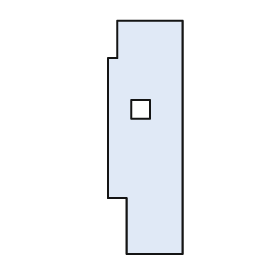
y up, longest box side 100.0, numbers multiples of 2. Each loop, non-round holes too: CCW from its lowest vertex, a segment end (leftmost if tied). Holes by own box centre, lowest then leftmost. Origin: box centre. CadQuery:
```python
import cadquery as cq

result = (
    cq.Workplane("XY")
    .moveTo(-8.0, -50.0)
    .lineTo(16.0, -50.0)
    .lineTo(16.0, 50.0)
    .lineTo(-12.0, 50.0)
    .lineTo(-12.0, 34.0)
    .lineTo(-16.0, 34.0)
    .lineTo(-16.0, -26.0)
    .lineTo(-8.0, -26.0)
    .close()
    .moveTo(-6.0, 8.0)
    .lineTo(2.0, 8.0)
    .lineTo(2.0, 16.0)
    .lineTo(-6.0, 16.0)
    .close()
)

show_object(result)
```